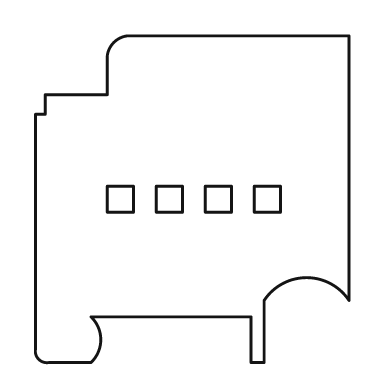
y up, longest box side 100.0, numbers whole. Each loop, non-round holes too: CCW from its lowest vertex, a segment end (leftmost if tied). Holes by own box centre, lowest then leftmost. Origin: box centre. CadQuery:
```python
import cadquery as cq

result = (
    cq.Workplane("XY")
    .moveTo(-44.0, -50.0)
    .lineTo(-31.0, -50.0)
    .threePointArc((-28.0, -43.0), (-31.0, -36.0))
    .lineTo(18.0, -36.0)
    .lineTo(18.0, -50.0)
    .lineTo(22.0, -50.0)
    .lineTo(22.0, -31.0)
    .threePointArc((35.0, -24.0), (48.0, -31.0))
    .lineTo(48.0, 50.0)
    .lineTo(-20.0, 50.0)
    .threePointArc((-24.0, 48.0), (-26.0, 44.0))
    .lineTo(-26.0, 32.0)
    .lineTo(-45.0, 32.0)
    .lineTo(-45.0, 26.0)
    .lineTo(-48.0, 26.0)
    .lineTo(-48.0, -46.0)
    .threePointArc((-47.0, -49.0), (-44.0, -50.0))
    .close()
    .moveTo(-26.0, -4.0)
    .lineTo(-18.0, -4.0)
    .lineTo(-18.0, 4.0)
    .lineTo(-26.0, 4.0)
    .close()
    .moveTo(-11.0, -4.0)
    .lineTo(-3.0, -4.0)
    .lineTo(-3.0, 4.0)
    .lineTo(-11.0, 4.0)
    .close()
    .moveTo(4.0, -4.0)
    .lineTo(12.0, -4.0)
    .lineTo(12.0, 4.0)
    .lineTo(4.0, 4.0)
    .close()
    .moveTo(19.0, -4.0)
    .lineTo(27.0, -4.0)
    .lineTo(27.0, 4.0)
    .lineTo(19.0, 4.0)
    .close()
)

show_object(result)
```